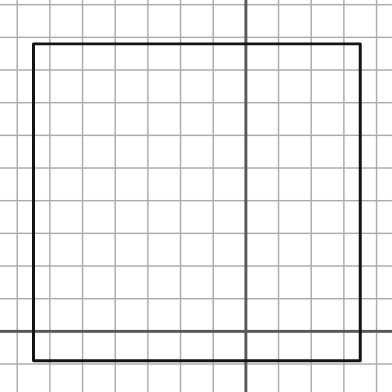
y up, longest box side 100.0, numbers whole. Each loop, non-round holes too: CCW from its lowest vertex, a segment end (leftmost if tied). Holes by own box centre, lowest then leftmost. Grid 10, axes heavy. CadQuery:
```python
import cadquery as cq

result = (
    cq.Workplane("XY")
    .moveTo(-65.0, -9.0)
    .lineTo(35.0, -9.0)
    .lineTo(35.0, 88.0)
    .lineTo(-65.0, 88.0)
    .close()
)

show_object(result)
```